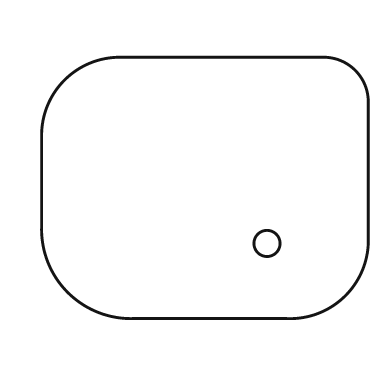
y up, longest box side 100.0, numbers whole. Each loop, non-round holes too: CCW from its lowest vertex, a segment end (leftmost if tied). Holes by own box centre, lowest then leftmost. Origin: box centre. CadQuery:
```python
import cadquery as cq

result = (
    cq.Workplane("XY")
    .moveTo(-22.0, -40.0)
    .lineTo(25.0, -40.0)
    .threePointArc((43.0, -33.0), (50.0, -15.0))
    .lineTo(50.0, 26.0)
    .threePointArc((46.0, 36.0), (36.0, 40.0))
    .lineTo(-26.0, 40.0)
    .threePointArc((-43.0, 33.0), (-50.0, 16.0))
    .lineTo(-50.0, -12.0)
    .threePointArc((-42.0, -32.0), (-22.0, -40.0))
    .close()
    .moveTo(19.0, -17.0)
    .circle(4.0)
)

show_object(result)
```